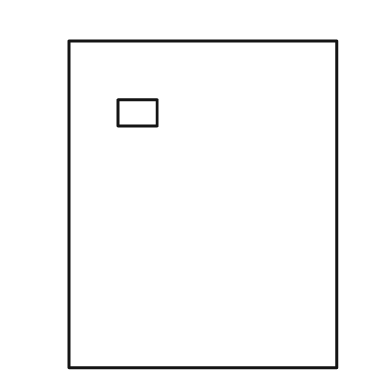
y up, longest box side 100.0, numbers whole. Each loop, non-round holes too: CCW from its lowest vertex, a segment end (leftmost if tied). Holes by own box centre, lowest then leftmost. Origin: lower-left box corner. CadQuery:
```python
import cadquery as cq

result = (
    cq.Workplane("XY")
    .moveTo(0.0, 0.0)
    .lineTo(82.0, 0.0)
    .lineTo(82.0, 100.0)
    .lineTo(0.0, 100.0)
    .close()
    .moveTo(15.0, 74.0)
    .lineTo(27.0, 74.0)
    .lineTo(27.0, 82.0)
    .lineTo(15.0, 82.0)
    .close()
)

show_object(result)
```